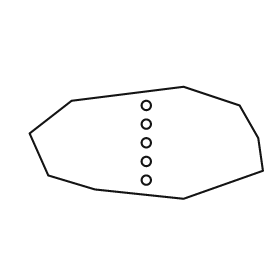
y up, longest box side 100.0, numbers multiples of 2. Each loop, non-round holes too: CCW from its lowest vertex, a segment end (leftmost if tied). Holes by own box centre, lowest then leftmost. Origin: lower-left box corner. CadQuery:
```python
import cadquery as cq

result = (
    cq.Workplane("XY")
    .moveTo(66.0, 0.0)
    .lineTo(100.0, 12.0)
    .lineTo(98.0, 26.0)
    .lineTo(90.0, 40.0)
    .lineTo(66.0, 48.0)
    .lineTo(18.0, 42.0)
    .lineTo(0.0, 28.0)
    .lineTo(8.0, 10.0)
    .lineTo(28.0, 4.0)
    .close()
    .moveTo(50.0, 8.0)
    .circle(2.0)
    .moveTo(50.0, 16.0)
    .circle(2.0)
    .moveTo(50.0, 24.0)
    .circle(2.0)
    .moveTo(50.0, 32.0)
    .circle(2.0)
    .moveTo(50.0, 40.0)
    .circle(2.0)
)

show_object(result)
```